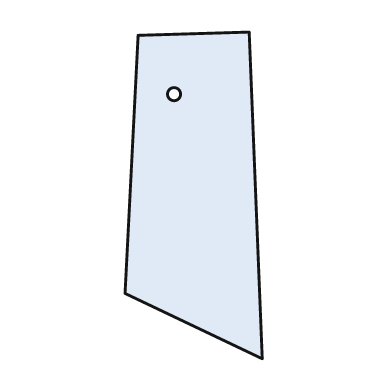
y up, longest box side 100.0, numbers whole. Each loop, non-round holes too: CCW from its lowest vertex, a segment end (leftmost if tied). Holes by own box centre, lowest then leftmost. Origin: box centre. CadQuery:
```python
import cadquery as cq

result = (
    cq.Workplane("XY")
    .moveTo(21.0, -50.0)
    .lineTo(17.0, 50.0)
    .lineTo(-17.0, 49.0)
    .lineTo(-21.0, -30.0)
    .close()
    .moveTo(-6.0, 31.0)
    .circle(2.0)
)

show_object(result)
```